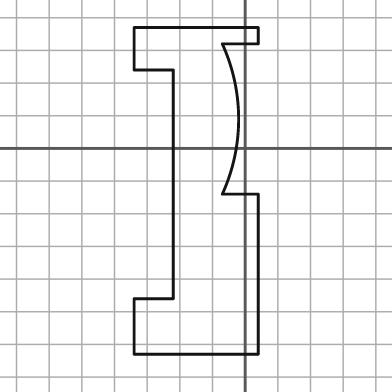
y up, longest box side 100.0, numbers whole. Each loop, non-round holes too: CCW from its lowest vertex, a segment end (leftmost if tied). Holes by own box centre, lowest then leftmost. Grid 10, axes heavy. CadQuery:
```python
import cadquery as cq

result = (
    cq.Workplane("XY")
    .moveTo(-34.0, -63.0)
    .lineTo(4.0, -63.0)
    .lineTo(4.0, -14.0)
    .lineTo(-7.0, -14.0)
    .threePointArc((-2.0, 9.0), (-7.0, 32.0))
    .lineTo(4.0, 32.0)
    .lineTo(4.0, 37.0)
    .lineTo(-34.0, 37.0)
    .lineTo(-34.0, 24.0)
    .lineTo(-22.0, 24.0)
    .lineTo(-22.0, -46.0)
    .lineTo(-34.0, -46.0)
    .close()
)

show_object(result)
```